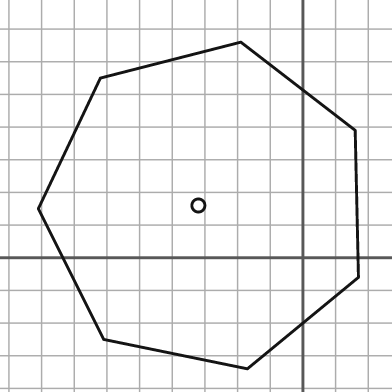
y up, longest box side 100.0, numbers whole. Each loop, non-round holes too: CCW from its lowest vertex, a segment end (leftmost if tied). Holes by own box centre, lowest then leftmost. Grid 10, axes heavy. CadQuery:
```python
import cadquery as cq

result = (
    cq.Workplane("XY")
    .moveTo(-17.0, -34.0)
    .lineTo(17.0, -6.0)
    .lineTo(16.0, 39.0)
    .lineTo(-19.0, 66.0)
    .lineTo(-62.0, 55.0)
    .lineTo(-81.0, 15.0)
    .lineTo(-61.0, -25.0)
    .close()
    .moveTo(-32.0, 16.0)
    .circle(2.0)
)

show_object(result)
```